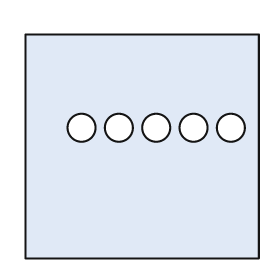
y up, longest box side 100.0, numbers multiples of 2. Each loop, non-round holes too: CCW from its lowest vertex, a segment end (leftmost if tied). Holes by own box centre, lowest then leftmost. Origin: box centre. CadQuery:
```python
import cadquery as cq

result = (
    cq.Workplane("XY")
    .moveTo(-50.0, -48.0)
    .lineTo(50.0, -48.0)
    .lineTo(50.0, 48.0)
    .lineTo(-50.0, 48.0)
    .close()
    .moveTo(-26.0, 8.0)
    .circle(6.0)
    .moveTo(-10.0, 8.0)
    .circle(6.0)
    .moveTo(6.0, 8.0)
    .circle(6.0)
    .moveTo(22.0, 8.0)
    .circle(6.0)
    .moveTo(38.0, 8.0)
    .circle(6.0)
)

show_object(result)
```